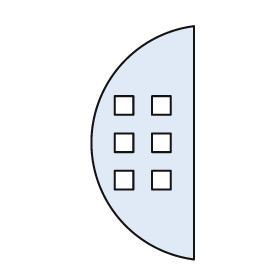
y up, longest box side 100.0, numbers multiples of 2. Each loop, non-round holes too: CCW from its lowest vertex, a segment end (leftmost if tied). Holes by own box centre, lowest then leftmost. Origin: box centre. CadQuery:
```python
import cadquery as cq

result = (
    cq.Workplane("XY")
    .moveTo(22.0, -50.0)
    .lineTo(22.0, 50.0)
    .threePointArc((-22.0, 0.0), (22.0, -50.0))
    .close()
    .moveTo(-12.0, -20.0)
    .lineTo(-4.0, -20.0)
    .lineTo(-4.0, -12.0)
    .lineTo(-12.0, -12.0)
    .close()
    .moveTo(4.0, -20.0)
    .lineTo(12.0, -20.0)
    .lineTo(12.0, -12.0)
    .lineTo(4.0, -12.0)
    .close()
    .moveTo(-12.0, -4.0)
    .lineTo(-4.0, -4.0)
    .lineTo(-4.0, 4.0)
    .lineTo(-12.0, 4.0)
    .close()
    .moveTo(4.0, -4.0)
    .lineTo(12.0, -4.0)
    .lineTo(12.0, 4.0)
    .lineTo(4.0, 4.0)
    .close()
    .moveTo(-12.0, 12.0)
    .lineTo(-4.0, 12.0)
    .lineTo(-4.0, 20.0)
    .lineTo(-12.0, 20.0)
    .close()
    .moveTo(4.0, 12.0)
    .lineTo(12.0, 12.0)
    .lineTo(12.0, 20.0)
    .lineTo(4.0, 20.0)
    .close()
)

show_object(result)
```